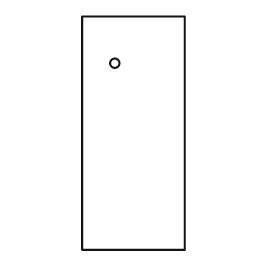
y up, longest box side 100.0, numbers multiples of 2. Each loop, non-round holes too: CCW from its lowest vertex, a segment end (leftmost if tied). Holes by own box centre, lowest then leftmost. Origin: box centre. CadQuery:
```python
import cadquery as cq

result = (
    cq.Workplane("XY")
    .moveTo(-22.0, -50.0)
    .lineTo(22.0, -50.0)
    .lineTo(22.0, 50.0)
    .lineTo(-22.0, 50.0)
    .close()
    .moveTo(-8.0, 30.0)
    .circle(2.0)
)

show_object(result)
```